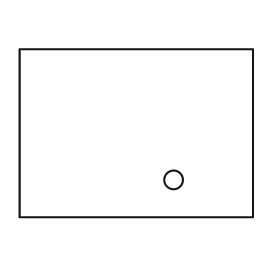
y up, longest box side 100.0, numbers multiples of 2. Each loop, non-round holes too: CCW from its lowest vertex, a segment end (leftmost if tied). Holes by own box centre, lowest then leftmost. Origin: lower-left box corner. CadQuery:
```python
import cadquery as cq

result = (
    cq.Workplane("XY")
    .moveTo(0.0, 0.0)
    .lineTo(100.0, 0.0)
    .lineTo(100.0, 72.0)
    .lineTo(0.0, 72.0)
    .close()
    .moveTo(66.0, 16.0)
    .circle(4.0)
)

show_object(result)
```